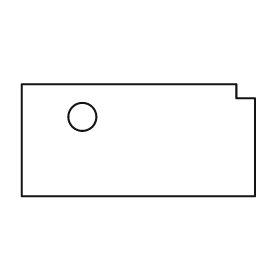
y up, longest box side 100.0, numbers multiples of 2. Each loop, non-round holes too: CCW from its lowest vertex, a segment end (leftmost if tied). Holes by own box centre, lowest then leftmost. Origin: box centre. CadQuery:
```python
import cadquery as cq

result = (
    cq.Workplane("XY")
    .moveTo(-50.0, -24.0)
    .lineTo(50.0, -24.0)
    .lineTo(50.0, 18.0)
    .lineTo(42.0, 18.0)
    .lineTo(42.0, 24.0)
    .lineTo(-50.0, 24.0)
    .close()
    .moveTo(-24.0, 10.0)
    .circle(6.0)
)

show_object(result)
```